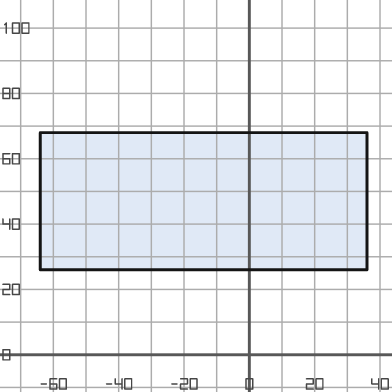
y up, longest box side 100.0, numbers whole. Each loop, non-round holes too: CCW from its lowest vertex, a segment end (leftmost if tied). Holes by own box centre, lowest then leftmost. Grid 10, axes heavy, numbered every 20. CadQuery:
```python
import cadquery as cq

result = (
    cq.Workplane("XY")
    .moveTo(-64.0, 26.0)
    .lineTo(36.0, 26.0)
    .lineTo(36.0, 68.0)
    .lineTo(-64.0, 68.0)
    .close()
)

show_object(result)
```